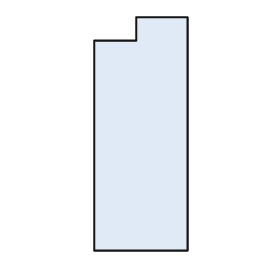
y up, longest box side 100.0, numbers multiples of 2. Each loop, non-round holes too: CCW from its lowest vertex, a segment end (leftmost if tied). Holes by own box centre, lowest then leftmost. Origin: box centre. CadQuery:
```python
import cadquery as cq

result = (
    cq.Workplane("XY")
    .moveTo(-20.0, -50.0)
    .lineTo(20.0, -50.0)
    .lineTo(20.0, 50.0)
    .lineTo(-2.0, 50.0)
    .lineTo(-2.0, 40.0)
    .lineTo(-20.0, 40.0)
    .close()
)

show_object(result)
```